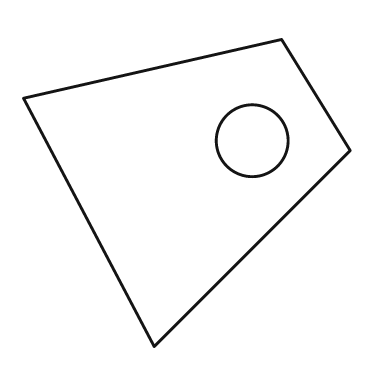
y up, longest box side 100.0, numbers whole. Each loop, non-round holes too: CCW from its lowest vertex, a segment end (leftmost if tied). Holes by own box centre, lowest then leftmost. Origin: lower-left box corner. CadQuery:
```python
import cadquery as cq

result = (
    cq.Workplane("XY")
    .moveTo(40.0, 0.0)
    .lineTo(100.0, 60.0)
    .lineTo(79.0, 94.0)
    .lineTo(0.0, 76.0)
    .close()
    .moveTo(70.0, 63.0)
    .circle(11.0)
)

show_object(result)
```